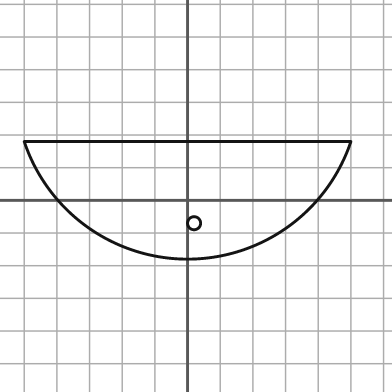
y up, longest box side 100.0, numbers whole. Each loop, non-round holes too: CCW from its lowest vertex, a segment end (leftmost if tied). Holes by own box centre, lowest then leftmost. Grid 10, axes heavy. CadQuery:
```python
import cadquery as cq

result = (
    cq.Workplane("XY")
    .moveTo(-50.0, 18.0)
    .threePointArc((0.0, -18.0), (50.0, 18.0))
    .close()
    .moveTo(2.0, -7.0)
    .circle(2.0)
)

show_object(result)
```